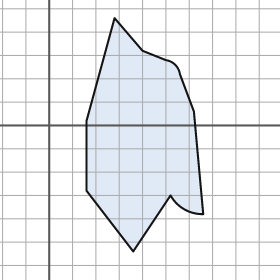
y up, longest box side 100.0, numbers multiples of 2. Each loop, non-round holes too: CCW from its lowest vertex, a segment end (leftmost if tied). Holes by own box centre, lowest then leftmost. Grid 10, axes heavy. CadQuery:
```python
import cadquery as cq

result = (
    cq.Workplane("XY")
    .moveTo(36.0, -54.0)
    .lineTo(52.0, -30.0)
    .threePointArc((58.0, -36.0), (66.0, -38.0))
    .lineTo(62.0, 6.0)
    .lineTo(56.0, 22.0)
    .threePointArc((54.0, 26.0), (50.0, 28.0))
    .lineTo(40.0, 32.0)
    .lineTo(28.0, 46.0)
    .lineTo(16.0, 2.0)
    .lineTo(16.0, -28.0)
    .close()
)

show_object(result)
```